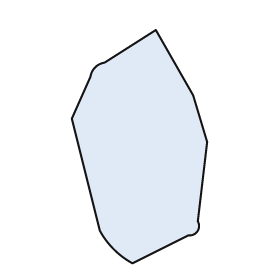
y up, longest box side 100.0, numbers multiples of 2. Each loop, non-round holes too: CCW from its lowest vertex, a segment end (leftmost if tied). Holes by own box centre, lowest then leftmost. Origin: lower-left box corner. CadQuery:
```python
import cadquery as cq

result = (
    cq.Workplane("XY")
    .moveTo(26.0, 0.0)
    .lineTo(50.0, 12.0)
    .threePointArc((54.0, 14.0), (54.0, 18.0))
    .lineTo(58.0, 52.0)
    .lineTo(52.0, 72.0)
    .lineTo(36.0, 100.0)
    .lineTo(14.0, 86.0)
    .threePointArc((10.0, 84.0), (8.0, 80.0))
    .lineTo(0.0, 62.0)
    .lineTo(12.0, 14.0)
    .threePointArc((18.0, 6.0), (26.0, 0.0))
    .close()
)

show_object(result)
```